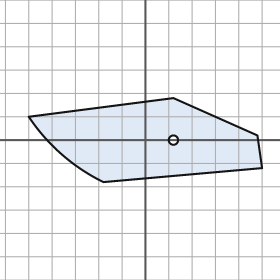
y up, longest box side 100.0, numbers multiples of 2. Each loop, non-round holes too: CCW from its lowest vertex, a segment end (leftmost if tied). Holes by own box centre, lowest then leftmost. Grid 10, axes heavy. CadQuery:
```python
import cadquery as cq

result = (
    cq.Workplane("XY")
    .moveTo(-18.0, -18.0)
    .lineTo(50.0, -12.0)
    .lineTo(48.0, 2.0)
    .lineTo(12.0, 18.0)
    .lineTo(-50.0, 10.0)
    .threePointArc((-36.0, -6.0), (-18.0, -18.0))
    .close()
    .moveTo(12.0, 0.0)
    .circle(2.0)
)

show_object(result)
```